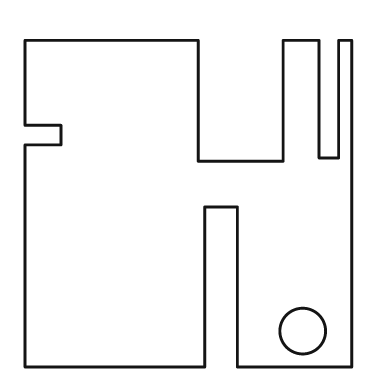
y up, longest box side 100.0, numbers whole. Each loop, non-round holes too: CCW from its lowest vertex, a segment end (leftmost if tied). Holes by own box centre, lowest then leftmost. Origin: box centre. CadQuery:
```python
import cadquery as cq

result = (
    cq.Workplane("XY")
    .moveTo(-50.0, -50.0)
    .lineTo(5.0, -50.0)
    .lineTo(5.0, -1.0)
    .lineTo(15.0, -1.0)
    .lineTo(15.0, -50.0)
    .lineTo(50.0, -50.0)
    .lineTo(50.0, 50.0)
    .lineTo(46.0, 50.0)
    .lineTo(46.0, 14.0)
    .lineTo(40.0, 14.0)
    .lineTo(40.0, 50.0)
    .lineTo(29.0, 50.0)
    .lineTo(29.0, 13.0)
    .lineTo(3.0, 13.0)
    .lineTo(3.0, 50.0)
    .lineTo(-50.0, 50.0)
    .lineTo(-50.0, 24.0)
    .lineTo(-39.0, 24.0)
    .lineTo(-39.0, 18.0)
    .lineTo(-50.0, 18.0)
    .close()
    .moveTo(35.0, -39.0)
    .circle(7.0)
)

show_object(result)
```